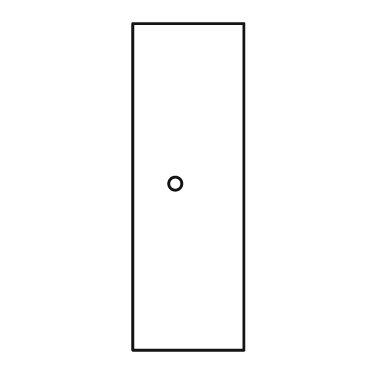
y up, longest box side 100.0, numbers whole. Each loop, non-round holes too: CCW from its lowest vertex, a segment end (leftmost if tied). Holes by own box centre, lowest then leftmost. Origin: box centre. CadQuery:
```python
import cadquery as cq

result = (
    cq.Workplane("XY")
    .moveTo(-17.0, -50.0)
    .lineTo(17.0, -50.0)
    .lineTo(17.0, 50.0)
    .lineTo(-17.0, 50.0)
    .close()
    .moveTo(-4.0, 1.0)
    .circle(2.0)
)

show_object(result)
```